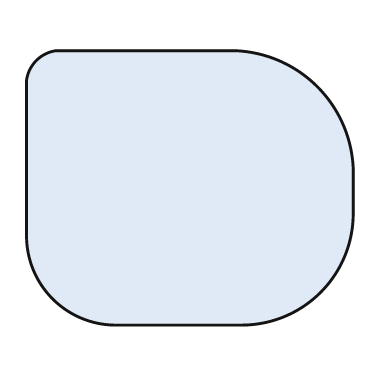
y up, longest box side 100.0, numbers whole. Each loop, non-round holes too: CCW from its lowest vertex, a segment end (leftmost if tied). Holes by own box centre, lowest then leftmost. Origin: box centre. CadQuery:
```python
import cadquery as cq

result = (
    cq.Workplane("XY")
    .moveTo(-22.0, -42.0)
    .lineTo(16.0, -42.0)
    .threePointArc((40.0, -32.0), (50.0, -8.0))
    .lineTo(50.0, 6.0)
    .threePointArc((39.0, 31.0), (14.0, 42.0))
    .lineTo(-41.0, 42.0)
    .threePointArc((-47.0, 39.0), (-50.0, 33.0))
    .lineTo(-50.0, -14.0)
    .threePointArc((-42.0, -34.0), (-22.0, -42.0))
    .close()
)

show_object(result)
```